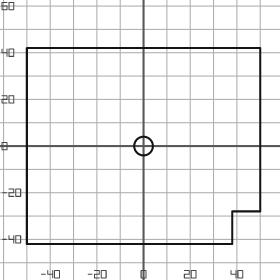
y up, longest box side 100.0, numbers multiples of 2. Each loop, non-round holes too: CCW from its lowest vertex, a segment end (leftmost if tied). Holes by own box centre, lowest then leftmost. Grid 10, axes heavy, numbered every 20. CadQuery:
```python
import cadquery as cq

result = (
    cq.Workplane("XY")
    .moveTo(-50.0, -42.0)
    .lineTo(38.0, -42.0)
    .lineTo(38.0, -28.0)
    .lineTo(50.0, -28.0)
    .lineTo(50.0, 42.0)
    .lineTo(-50.0, 42.0)
    .close()
    .moveTo(0.0, 0.0)
    .circle(4.0)
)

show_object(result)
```